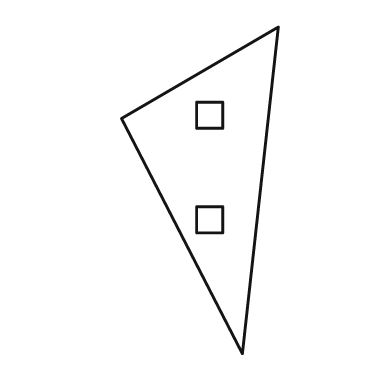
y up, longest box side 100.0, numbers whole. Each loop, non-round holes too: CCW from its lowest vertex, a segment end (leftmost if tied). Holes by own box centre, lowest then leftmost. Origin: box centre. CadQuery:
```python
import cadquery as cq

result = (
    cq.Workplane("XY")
    .moveTo(13.0, -50.0)
    .lineTo(24.0, 50.0)
    .lineTo(-24.0, 22.0)
    .close()
    .moveTo(-1.0, -13.0)
    .lineTo(7.0, -13.0)
    .lineTo(7.0, -5.0)
    .lineTo(-1.0, -5.0)
    .close()
    .moveTo(-1.0, 19.0)
    .lineTo(7.0, 19.0)
    .lineTo(7.0, 27.0)
    .lineTo(-1.0, 27.0)
    .close()
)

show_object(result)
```